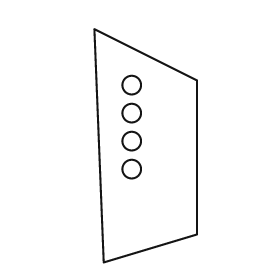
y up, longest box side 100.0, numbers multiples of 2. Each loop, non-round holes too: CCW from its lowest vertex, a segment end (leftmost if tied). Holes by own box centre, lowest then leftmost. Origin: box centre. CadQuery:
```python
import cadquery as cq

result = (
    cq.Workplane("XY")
    .moveTo(-18.0, -50.0)
    .lineTo(22.0, -38.0)
    .lineTo(22.0, 28.0)
    .lineTo(-22.0, 50.0)
    .close()
    .moveTo(-6.0, -10.0)
    .circle(4.0)
    .moveTo(-6.0, 2.0)
    .circle(4.0)
    .moveTo(-6.0, 14.0)
    .circle(4.0)
    .moveTo(-6.0, 26.0)
    .circle(4.0)
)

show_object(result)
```